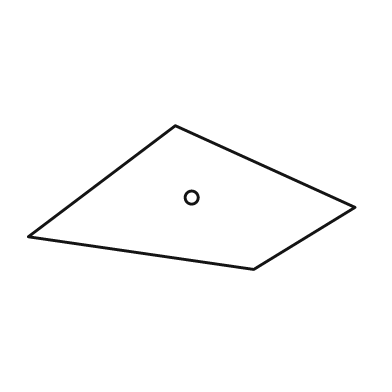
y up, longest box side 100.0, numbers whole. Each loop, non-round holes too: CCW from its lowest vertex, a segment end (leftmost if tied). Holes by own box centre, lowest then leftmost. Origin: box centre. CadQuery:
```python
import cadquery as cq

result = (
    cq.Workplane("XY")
    .moveTo(19.0, -22.0)
    .lineTo(50.0, -3.0)
    .lineTo(-5.0, 22.0)
    .lineTo(-50.0, -12.0)
    .close()
    .moveTo(0.0, 0.0)
    .circle(2.0)
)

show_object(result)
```